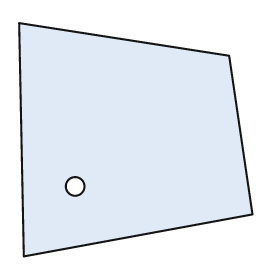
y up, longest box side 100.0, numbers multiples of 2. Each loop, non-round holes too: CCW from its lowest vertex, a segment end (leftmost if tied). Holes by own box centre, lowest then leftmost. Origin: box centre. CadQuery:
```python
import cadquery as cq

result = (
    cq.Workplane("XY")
    .moveTo(-48.0, -50.0)
    .lineTo(50.0, -32.0)
    .lineTo(40.0, 36.0)
    .lineTo(-50.0, 50.0)
    .close()
    .moveTo(-26.0, -20.0)
    .circle(4.0)
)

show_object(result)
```